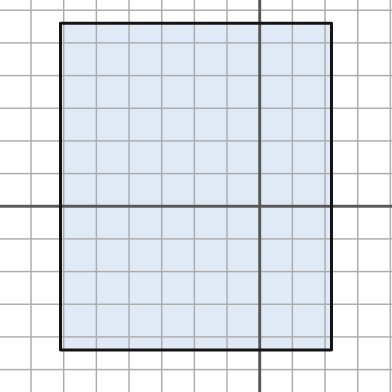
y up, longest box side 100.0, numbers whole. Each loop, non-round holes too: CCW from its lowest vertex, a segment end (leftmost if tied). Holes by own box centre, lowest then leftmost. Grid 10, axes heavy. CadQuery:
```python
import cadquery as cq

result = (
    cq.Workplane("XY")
    .moveTo(-61.0, -44.0)
    .lineTo(22.0, -44.0)
    .lineTo(22.0, 56.0)
    .lineTo(-61.0, 56.0)
    .close()
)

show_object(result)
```